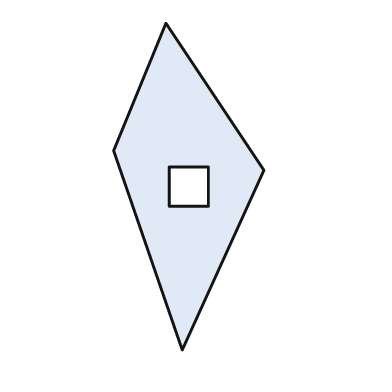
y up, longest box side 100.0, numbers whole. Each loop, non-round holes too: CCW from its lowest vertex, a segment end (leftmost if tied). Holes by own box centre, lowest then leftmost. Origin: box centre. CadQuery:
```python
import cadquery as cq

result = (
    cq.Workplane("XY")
    .moveTo(-2.0, -50.0)
    .lineTo(23.0, 5.0)
    .lineTo(-7.0, 50.0)
    .lineTo(-23.0, 11.0)
    .close()
    .moveTo(-6.0, -6.0)
    .lineTo(6.0, -6.0)
    .lineTo(6.0, 6.0)
    .lineTo(-6.0, 6.0)
    .close()
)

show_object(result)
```